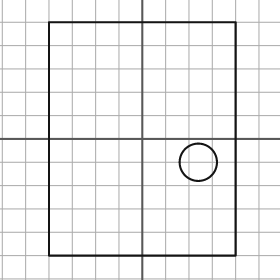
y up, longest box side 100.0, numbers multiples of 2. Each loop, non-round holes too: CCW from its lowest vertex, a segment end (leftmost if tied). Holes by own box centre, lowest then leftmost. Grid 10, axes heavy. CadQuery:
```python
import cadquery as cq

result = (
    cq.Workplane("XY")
    .moveTo(-40.0, -50.0)
    .lineTo(40.0, -50.0)
    .lineTo(40.0, 50.0)
    .lineTo(-40.0, 50.0)
    .close()
    .moveTo(24.0, -10.0)
    .circle(8.0)
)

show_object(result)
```